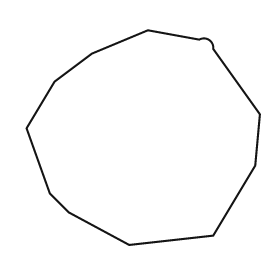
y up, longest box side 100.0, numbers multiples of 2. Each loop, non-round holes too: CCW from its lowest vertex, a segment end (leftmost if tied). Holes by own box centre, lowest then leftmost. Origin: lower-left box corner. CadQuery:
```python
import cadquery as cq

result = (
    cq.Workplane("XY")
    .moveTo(44.0, 0.0)
    .lineTo(80.0, 4.0)
    .lineTo(98.0, 34.0)
    .lineTo(100.0, 56.0)
    .lineTo(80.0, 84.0)
    .threePointArc((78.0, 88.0), (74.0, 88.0))
    .lineTo(52.0, 92.0)
    .lineTo(28.0, 82.0)
    .lineTo(12.0, 70.0)
    .lineTo(0.0, 50.0)
    .lineTo(10.0, 22.0)
    .lineTo(18.0, 14.0)
    .close()
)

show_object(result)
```